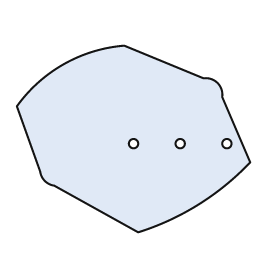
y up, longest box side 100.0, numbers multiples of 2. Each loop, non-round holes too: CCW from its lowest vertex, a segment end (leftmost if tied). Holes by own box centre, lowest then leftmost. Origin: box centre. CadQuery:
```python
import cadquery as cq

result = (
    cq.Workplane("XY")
    .moveTo(2.0, -40.0)
    .threePointArc((28.0, -28.0), (50.0, -10.0))
    .lineTo(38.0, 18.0)
    .threePointArc((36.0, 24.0), (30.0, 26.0))
    .lineTo(-4.0, 40.0)
    .threePointArc((-30.0, 32.0), (-50.0, 14.0))
    .lineTo(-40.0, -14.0)
    .threePointArc((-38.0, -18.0), (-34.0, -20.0))
    .close()
    .moveTo(0.0, -2.0)
    .circle(2.0)
    .moveTo(20.0, -2.0)
    .circle(2.0)
    .moveTo(40.0, -2.0)
    .circle(2.0)
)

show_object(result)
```